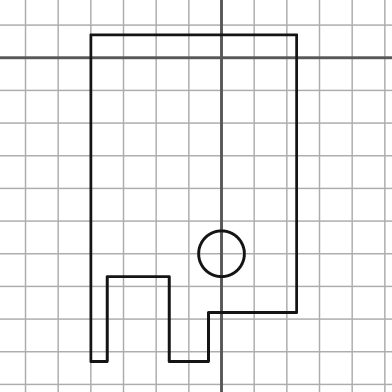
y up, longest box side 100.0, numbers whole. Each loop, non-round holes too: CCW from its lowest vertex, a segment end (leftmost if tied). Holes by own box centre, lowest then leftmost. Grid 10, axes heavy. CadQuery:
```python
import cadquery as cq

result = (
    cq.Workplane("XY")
    .moveTo(-40.0, -93.0)
    .lineTo(-35.0, -93.0)
    .lineTo(-35.0, -67.0)
    .lineTo(-16.0, -67.0)
    .lineTo(-16.0, -93.0)
    .lineTo(-4.0, -93.0)
    .lineTo(-4.0, -78.0)
    .lineTo(23.0, -78.0)
    .lineTo(23.0, 7.0)
    .lineTo(-40.0, 7.0)
    .close()
    .moveTo(0.0, -60.0)
    .circle(7.0)
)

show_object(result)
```